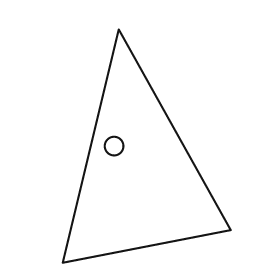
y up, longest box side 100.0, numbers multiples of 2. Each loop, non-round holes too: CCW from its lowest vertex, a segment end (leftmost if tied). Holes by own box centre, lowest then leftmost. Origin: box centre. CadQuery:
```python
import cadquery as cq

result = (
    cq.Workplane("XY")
    .moveTo(-36.0, -50.0)
    .lineTo(36.0, -36.0)
    .lineTo(-12.0, 50.0)
    .close()
    .moveTo(-14.0, 0.0)
    .circle(4.0)
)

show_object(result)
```